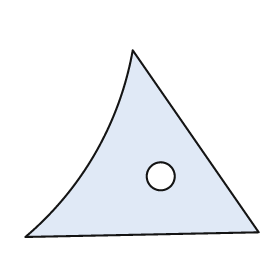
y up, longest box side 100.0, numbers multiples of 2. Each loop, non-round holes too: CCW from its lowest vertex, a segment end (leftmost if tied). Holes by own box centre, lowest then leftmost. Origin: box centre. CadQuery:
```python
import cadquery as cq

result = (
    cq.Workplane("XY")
    .moveTo(-50.0, -40.0)
    .lineTo(50.0, -38.0)
    .lineTo(-4.0, 40.0)
    .threePointArc((-20.0, -4.0), (-50.0, -40.0))
    .close()
    .moveTo(8.0, -14.0)
    .circle(6.0)
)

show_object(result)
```